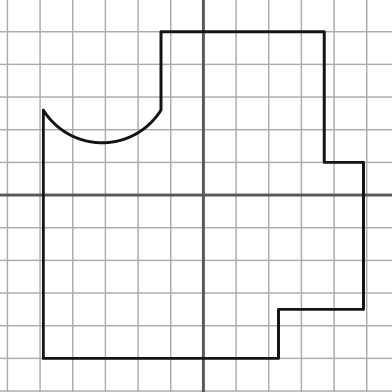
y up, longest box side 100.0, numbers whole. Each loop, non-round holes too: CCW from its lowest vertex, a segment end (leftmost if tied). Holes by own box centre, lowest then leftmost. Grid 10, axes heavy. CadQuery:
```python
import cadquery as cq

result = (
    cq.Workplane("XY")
    .moveTo(-49.0, -50.0)
    .lineTo(23.0, -50.0)
    .lineTo(23.0, -35.0)
    .lineTo(49.0, -35.0)
    .lineTo(49.0, 10.0)
    .lineTo(37.0, 10.0)
    .lineTo(37.0, 50.0)
    .lineTo(-13.0, 50.0)
    .lineTo(-13.0, 26.0)
    .threePointArc((-31.0, 16.0), (-49.0, 26.0))
    .close()
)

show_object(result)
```